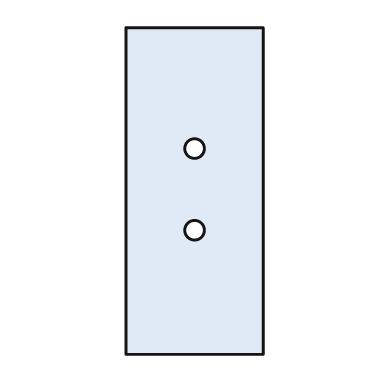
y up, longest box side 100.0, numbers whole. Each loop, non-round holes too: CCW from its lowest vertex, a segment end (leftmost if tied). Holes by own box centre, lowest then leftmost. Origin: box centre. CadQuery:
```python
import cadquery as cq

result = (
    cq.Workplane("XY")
    .moveTo(-21.0, -50.0)
    .lineTo(21.0, -50.0)
    .lineTo(21.0, 50.0)
    .lineTo(-21.0, 50.0)
    .close()
    .moveTo(0.0, -12.0)
    .circle(3.0)
    .moveTo(0.0, 13.0)
    .circle(3.0)
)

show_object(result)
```